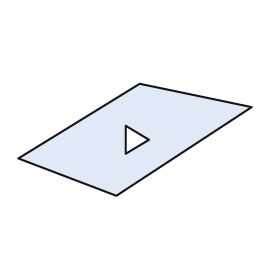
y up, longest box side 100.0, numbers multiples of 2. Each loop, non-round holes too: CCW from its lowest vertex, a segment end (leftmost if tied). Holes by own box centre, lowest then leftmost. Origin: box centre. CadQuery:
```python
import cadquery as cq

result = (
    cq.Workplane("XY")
    .moveTo(-8.0, -24.0)
    .lineTo(50.0, 14.0)
    .lineTo(2.0, 24.0)
    .lineTo(-50.0, -8.0)
    .close()
    .moveTo(-4.0, -6.0)
    .lineTo(6.0, 0.0)
    .lineTo(-4.0, 6.0)
    .close()
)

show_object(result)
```